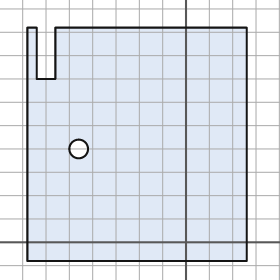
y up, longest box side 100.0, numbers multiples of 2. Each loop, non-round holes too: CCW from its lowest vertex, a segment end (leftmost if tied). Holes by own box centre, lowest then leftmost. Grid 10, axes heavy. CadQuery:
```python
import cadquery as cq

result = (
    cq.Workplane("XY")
    .moveTo(-68.0, -8.0)
    .lineTo(26.0, -8.0)
    .lineTo(26.0, 92.0)
    .lineTo(-56.0, 92.0)
    .lineTo(-56.0, 70.0)
    .lineTo(-64.0, 70.0)
    .lineTo(-64.0, 92.0)
    .lineTo(-68.0, 92.0)
    .close()
    .moveTo(-46.0, 40.0)
    .circle(4.0)
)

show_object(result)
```